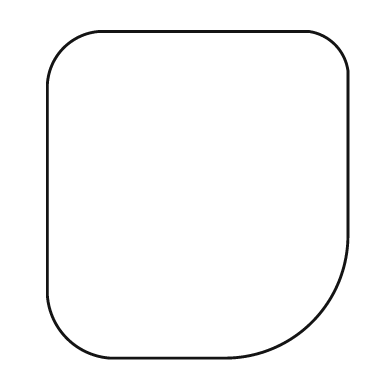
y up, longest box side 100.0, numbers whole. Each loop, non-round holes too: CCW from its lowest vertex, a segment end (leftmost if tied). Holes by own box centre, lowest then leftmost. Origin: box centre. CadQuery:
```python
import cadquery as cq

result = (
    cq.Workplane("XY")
    .moveTo(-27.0, -50.0)
    .lineTo(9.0, -50.0)
    .threePointArc((35.0, -39.0), (46.0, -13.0))
    .lineTo(46.0, 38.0)
    .threePointArc((42.0, 46.0), (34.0, 50.0))
    .lineTo(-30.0, 50.0)
    .threePointArc((-41.0, 45.0), (-46.0, 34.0))
    .lineTo(-46.0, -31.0)
    .threePointArc((-40.0, -44.0), (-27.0, -50.0))
    .close()
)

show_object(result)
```